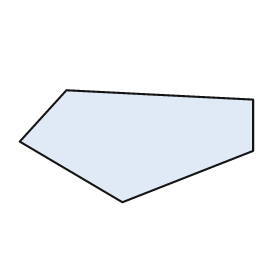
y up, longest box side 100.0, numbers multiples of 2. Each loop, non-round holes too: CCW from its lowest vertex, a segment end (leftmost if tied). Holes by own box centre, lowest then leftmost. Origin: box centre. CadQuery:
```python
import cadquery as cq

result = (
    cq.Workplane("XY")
    .moveTo(-6.0, -24.0)
    .lineTo(50.0, -2.0)
    .lineTo(50.0, 20.0)
    .lineTo(-30.0, 24.0)
    .lineTo(-50.0, 2.0)
    .close()
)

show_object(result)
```